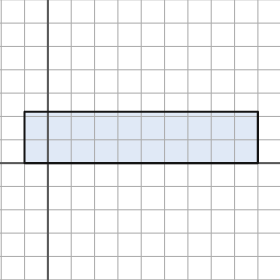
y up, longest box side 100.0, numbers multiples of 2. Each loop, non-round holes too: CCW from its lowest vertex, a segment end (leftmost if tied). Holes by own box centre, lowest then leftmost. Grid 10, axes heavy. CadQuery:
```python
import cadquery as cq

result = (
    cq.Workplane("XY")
    .moveTo(-10.0, 0.0)
    .lineTo(90.0, 0.0)
    .lineTo(90.0, 22.0)
    .lineTo(-10.0, 22.0)
    .close()
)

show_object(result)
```